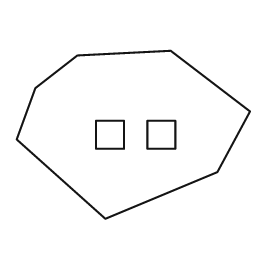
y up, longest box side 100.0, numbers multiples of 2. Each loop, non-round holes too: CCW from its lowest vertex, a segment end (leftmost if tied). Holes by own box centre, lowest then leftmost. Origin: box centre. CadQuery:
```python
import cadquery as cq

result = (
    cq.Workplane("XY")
    .moveTo(-12.0, -36.0)
    .lineTo(36.0, -16.0)
    .lineTo(50.0, 10.0)
    .lineTo(16.0, 36.0)
    .lineTo(-24.0, 34.0)
    .lineTo(-42.0, 20.0)
    .lineTo(-50.0, -2.0)
    .close()
    .moveTo(-16.0, -6.0)
    .lineTo(-4.0, -6.0)
    .lineTo(-4.0, 6.0)
    .lineTo(-16.0, 6.0)
    .close()
    .moveTo(6.0, -6.0)
    .lineTo(18.0, -6.0)
    .lineTo(18.0, 6.0)
    .lineTo(6.0, 6.0)
    .close()
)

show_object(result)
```